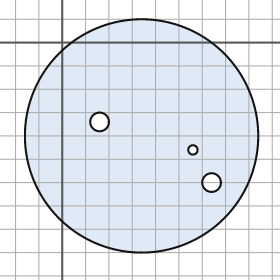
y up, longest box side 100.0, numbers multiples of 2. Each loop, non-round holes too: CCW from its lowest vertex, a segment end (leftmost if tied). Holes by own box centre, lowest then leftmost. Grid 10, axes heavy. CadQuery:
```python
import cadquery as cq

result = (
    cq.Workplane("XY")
    .moveTo(34.0, -40.0)
    .circle(50.0)
    .moveTo(64.0, -60.0)
    .circle(4.0)
    .moveTo(56.0, -46.0)
    .circle(2.0)
    .moveTo(16.0, -34.0)
    .circle(4.0)
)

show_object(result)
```